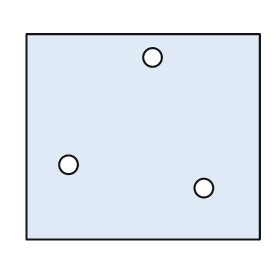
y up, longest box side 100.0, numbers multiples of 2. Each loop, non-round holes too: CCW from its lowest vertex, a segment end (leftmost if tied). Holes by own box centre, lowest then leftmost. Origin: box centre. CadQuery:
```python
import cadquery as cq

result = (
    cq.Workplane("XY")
    .moveTo(-50.0, -44.0)
    .lineTo(50.0, -44.0)
    .lineTo(50.0, 44.0)
    .lineTo(-50.0, 44.0)
    .close()
    .moveTo(26.0, -22.0)
    .circle(4.0)
    .moveTo(-32.0, -12.0)
    .circle(4.0)
    .moveTo(4.0, 34.0)
    .circle(4.0)
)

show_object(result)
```